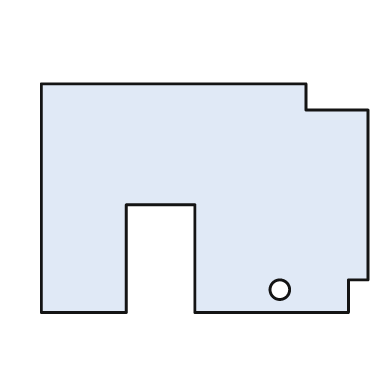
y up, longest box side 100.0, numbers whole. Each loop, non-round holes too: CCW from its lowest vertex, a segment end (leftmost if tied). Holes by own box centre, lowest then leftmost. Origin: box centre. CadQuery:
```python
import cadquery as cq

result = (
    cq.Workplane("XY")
    .moveTo(-50.0, -35.0)
    .lineTo(-24.0, -35.0)
    .lineTo(-24.0, -2.0)
    .lineTo(-3.0, -2.0)
    .lineTo(-3.0, -35.0)
    .lineTo(44.0, -35.0)
    .lineTo(44.0, -25.0)
    .lineTo(50.0, -25.0)
    .lineTo(50.0, 27.0)
    .lineTo(31.0, 27.0)
    .lineTo(31.0, 35.0)
    .lineTo(-50.0, 35.0)
    .close()
    .moveTo(23.0, -28.0)
    .circle(3.0)
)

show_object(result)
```